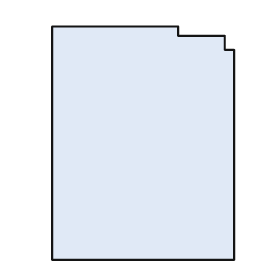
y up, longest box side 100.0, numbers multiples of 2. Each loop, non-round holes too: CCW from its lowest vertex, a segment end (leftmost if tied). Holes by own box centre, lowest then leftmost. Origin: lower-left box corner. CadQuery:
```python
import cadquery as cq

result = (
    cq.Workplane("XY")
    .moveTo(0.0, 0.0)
    .lineTo(78.0, 0.0)
    .lineTo(78.0, 90.0)
    .lineTo(74.0, 90.0)
    .lineTo(74.0, 96.0)
    .lineTo(54.0, 96.0)
    .lineTo(54.0, 100.0)
    .lineTo(0.0, 100.0)
    .close()
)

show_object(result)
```